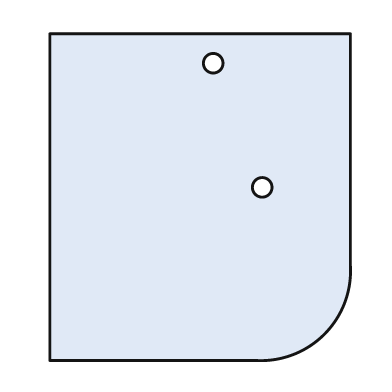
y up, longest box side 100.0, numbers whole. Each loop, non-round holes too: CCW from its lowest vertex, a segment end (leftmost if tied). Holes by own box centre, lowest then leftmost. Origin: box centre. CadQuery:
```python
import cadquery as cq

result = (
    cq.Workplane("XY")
    .moveTo(-46.0, -50.0)
    .lineTo(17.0, -50.0)
    .threePointArc((38.0, -42.0), (46.0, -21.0))
    .lineTo(46.0, 50.0)
    .lineTo(-46.0, 50.0)
    .close()
    .moveTo(19.0, 3.0)
    .circle(3.0)
    .moveTo(4.0, 41.0)
    .circle(3.0)
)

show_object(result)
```